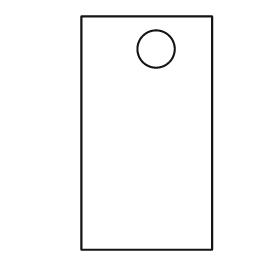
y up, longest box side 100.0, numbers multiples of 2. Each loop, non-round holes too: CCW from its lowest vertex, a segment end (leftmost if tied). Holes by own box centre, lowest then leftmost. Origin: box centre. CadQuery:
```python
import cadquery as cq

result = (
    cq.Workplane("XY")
    .moveTo(-28.0, -50.0)
    .lineTo(28.0, -50.0)
    .lineTo(28.0, 50.0)
    .lineTo(-28.0, 50.0)
    .close()
    .moveTo(4.0, 36.0)
    .circle(8.0)
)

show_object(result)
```